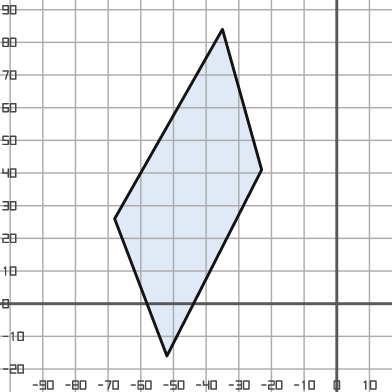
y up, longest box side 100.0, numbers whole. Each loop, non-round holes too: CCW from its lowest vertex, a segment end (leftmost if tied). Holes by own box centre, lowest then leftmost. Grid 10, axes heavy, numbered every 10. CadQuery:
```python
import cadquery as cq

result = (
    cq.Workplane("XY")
    .moveTo(-52.0, -16.0)
    .lineTo(-23.0, 41.0)
    .lineTo(-35.0, 84.0)
    .lineTo(-68.0, 26.0)
    .close()
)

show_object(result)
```